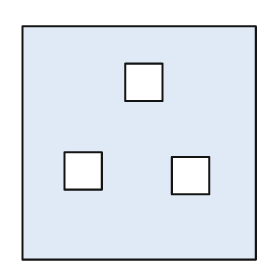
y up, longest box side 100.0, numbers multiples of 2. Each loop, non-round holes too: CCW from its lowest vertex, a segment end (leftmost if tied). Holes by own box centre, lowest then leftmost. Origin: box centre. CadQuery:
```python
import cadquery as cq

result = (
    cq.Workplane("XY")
    .moveTo(-50.0, -50.0)
    .lineTo(50.0, -50.0)
    .lineTo(50.0, 50.0)
    .lineTo(-50.0, 50.0)
    .close()
    .moveTo(14.0, -22.0)
    .lineTo(30.0, -22.0)
    .lineTo(30.0, -6.0)
    .lineTo(14.0, -6.0)
    .close()
    .moveTo(-32.0, -20.0)
    .lineTo(-16.0, -20.0)
    .lineTo(-16.0, -4.0)
    .lineTo(-32.0, -4.0)
    .close()
    .moveTo(-6.0, 18.0)
    .lineTo(10.0, 18.0)
    .lineTo(10.0, 34.0)
    .lineTo(-6.0, 34.0)
    .close()
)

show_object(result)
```